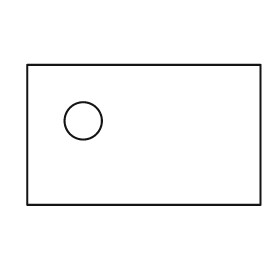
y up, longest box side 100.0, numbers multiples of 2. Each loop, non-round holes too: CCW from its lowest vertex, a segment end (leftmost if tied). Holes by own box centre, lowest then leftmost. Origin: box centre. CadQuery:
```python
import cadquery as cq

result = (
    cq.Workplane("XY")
    .moveTo(-50.0, -30.0)
    .lineTo(50.0, -30.0)
    .lineTo(50.0, 30.0)
    .lineTo(-50.0, 30.0)
    .close()
    .moveTo(-26.0, 6.0)
    .circle(8.0)
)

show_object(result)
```